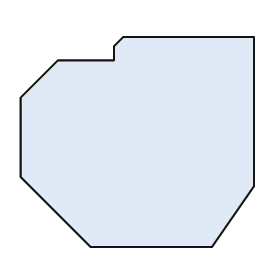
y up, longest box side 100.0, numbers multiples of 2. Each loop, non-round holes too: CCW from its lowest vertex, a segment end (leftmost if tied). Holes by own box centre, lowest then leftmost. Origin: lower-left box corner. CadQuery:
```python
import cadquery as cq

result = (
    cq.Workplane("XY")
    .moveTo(30.0, 0.0)
    .lineTo(82.0, 0.0)
    .lineTo(100.0, 26.0)
    .lineTo(100.0, 90.0)
    .lineTo(44.0, 90.0)
    .lineTo(40.0, 86.0)
    .lineTo(40.0, 80.0)
    .lineTo(16.0, 80.0)
    .lineTo(0.0, 64.0)
    .lineTo(0.0, 30.0)
    .close()
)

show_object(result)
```